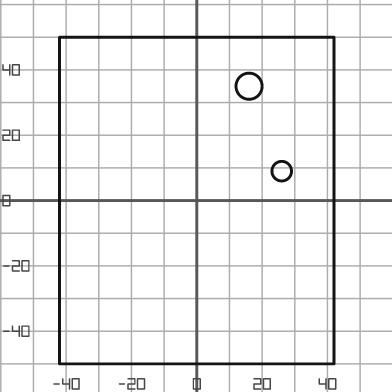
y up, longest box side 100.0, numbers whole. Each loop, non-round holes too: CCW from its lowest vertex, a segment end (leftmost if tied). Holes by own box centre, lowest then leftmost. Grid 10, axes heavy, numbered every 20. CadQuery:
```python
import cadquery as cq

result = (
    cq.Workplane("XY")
    .moveTo(-42.0, -50.0)
    .lineTo(42.0, -50.0)
    .lineTo(42.0, 50.0)
    .lineTo(-42.0, 50.0)
    .close()
    .moveTo(26.0, 9.0)
    .circle(3.0)
    .moveTo(16.0, 35.0)
    .circle(4.0)
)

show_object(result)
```